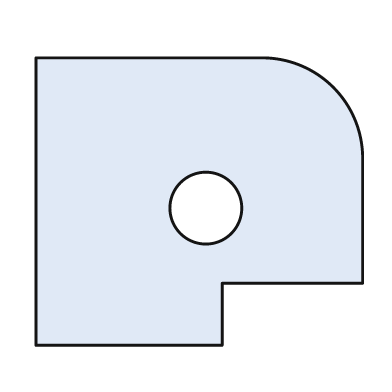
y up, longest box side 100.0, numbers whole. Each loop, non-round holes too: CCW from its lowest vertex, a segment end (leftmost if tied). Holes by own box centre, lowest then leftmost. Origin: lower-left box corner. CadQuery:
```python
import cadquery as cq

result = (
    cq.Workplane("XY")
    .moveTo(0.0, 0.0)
    .lineTo(57.0, 0.0)
    .lineTo(57.0, 19.0)
    .lineTo(100.0, 19.0)
    .lineTo(100.0, 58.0)
    .threePointArc((91.0, 79.0), (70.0, 88.0))
    .lineTo(0.0, 88.0)
    .close()
    .moveTo(52.0, 42.0)
    .circle(11.0)
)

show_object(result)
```